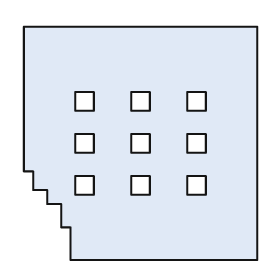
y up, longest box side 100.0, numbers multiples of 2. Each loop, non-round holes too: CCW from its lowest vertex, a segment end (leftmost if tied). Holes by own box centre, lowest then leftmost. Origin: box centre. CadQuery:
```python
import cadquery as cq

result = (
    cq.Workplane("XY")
    .moveTo(-30.0, -50.0)
    .lineTo(50.0, -50.0)
    .lineTo(50.0, 50.0)
    .lineTo(-50.0, 50.0)
    .lineTo(-50.0, -12.0)
    .lineTo(-46.0, -12.0)
    .lineTo(-46.0, -20.0)
    .lineTo(-40.0, -20.0)
    .lineTo(-40.0, -26.0)
    .lineTo(-34.0, -26.0)
    .lineTo(-34.0, -36.0)
    .lineTo(-30.0, -36.0)
    .close()
    .moveTo(-28.0, -22.0)
    .lineTo(-20.0, -22.0)
    .lineTo(-20.0, -14.0)
    .lineTo(-28.0, -14.0)
    .close()
    .moveTo(-4.0, -22.0)
    .lineTo(4.0, -22.0)
    .lineTo(4.0, -14.0)
    .lineTo(-4.0, -14.0)
    .close()
    .moveTo(20.0, -22.0)
    .lineTo(28.0, -22.0)
    .lineTo(28.0, -14.0)
    .lineTo(20.0, -14.0)
    .close()
    .moveTo(-28.0, -4.0)
    .lineTo(-20.0, -4.0)
    .lineTo(-20.0, 4.0)
    .lineTo(-28.0, 4.0)
    .close()
    .moveTo(-4.0, -4.0)
    .lineTo(4.0, -4.0)
    .lineTo(4.0, 4.0)
    .lineTo(-4.0, 4.0)
    .close()
    .moveTo(20.0, -4.0)
    .lineTo(28.0, -4.0)
    .lineTo(28.0, 4.0)
    .lineTo(20.0, 4.0)
    .close()
    .moveTo(-28.0, 14.0)
    .lineTo(-20.0, 14.0)
    .lineTo(-20.0, 22.0)
    .lineTo(-28.0, 22.0)
    .close()
    .moveTo(-4.0, 14.0)
    .lineTo(4.0, 14.0)
    .lineTo(4.0, 22.0)
    .lineTo(-4.0, 22.0)
    .close()
    .moveTo(20.0, 14.0)
    .lineTo(28.0, 14.0)
    .lineTo(28.0, 22.0)
    .lineTo(20.0, 22.0)
    .close()
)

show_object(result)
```